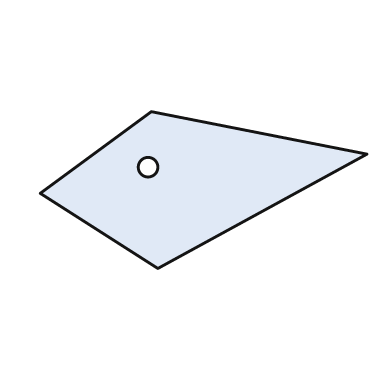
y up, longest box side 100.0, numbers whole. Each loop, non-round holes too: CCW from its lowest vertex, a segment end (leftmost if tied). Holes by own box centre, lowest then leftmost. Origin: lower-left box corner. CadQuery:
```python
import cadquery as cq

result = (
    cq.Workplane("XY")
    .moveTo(36.0, 0.0)
    .lineTo(100.0, 35.0)
    .lineTo(34.0, 48.0)
    .lineTo(0.0, 23.0)
    .close()
    .moveTo(33.0, 31.0)
    .circle(3.0)
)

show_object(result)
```